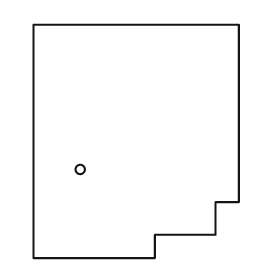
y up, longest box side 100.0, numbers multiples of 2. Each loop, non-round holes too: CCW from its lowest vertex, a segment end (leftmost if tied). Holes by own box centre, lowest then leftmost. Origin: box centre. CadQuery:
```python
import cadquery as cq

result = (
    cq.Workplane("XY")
    .moveTo(-44.0, -50.0)
    .lineTo(8.0, -50.0)
    .lineTo(8.0, -40.0)
    .lineTo(34.0, -40.0)
    .lineTo(34.0, -26.0)
    .lineTo(44.0, -26.0)
    .lineTo(44.0, 50.0)
    .lineTo(-44.0, 50.0)
    .close()
    .moveTo(-24.0, -12.0)
    .circle(2.0)
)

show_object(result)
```